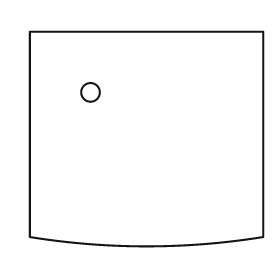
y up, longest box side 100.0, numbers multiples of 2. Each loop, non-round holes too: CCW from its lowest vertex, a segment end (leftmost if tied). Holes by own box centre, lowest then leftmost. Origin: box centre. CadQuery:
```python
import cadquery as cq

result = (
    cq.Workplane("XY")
    .moveTo(-50.0, -42.0)
    .threePointArc((0.0, -46.0), (50.0, -42.0))
    .lineTo(50.0, 46.0)
    .lineTo(-50.0, 46.0)
    .close()
    .moveTo(-24.0, 20.0)
    .circle(4.0)
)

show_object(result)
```